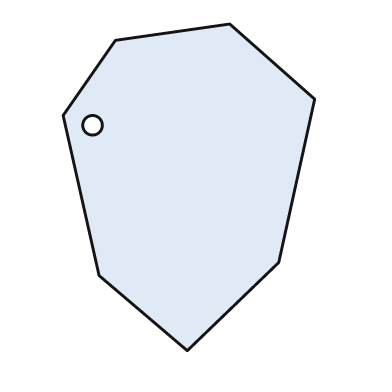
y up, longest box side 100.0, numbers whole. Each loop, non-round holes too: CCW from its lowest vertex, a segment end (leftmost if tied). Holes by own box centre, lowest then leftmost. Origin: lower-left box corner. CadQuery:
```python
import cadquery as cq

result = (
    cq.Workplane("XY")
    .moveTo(38.0, 0.0)
    .lineTo(66.0, 27.0)
    .lineTo(77.0, 77.0)
    .lineTo(51.0, 100.0)
    .lineTo(16.0, 95.0)
    .lineTo(0.0, 72.0)
    .lineTo(11.0, 23.0)
    .close()
    .moveTo(9.0, 69.0)
    .circle(3.0)
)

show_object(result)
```